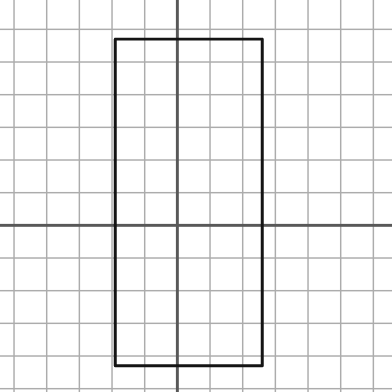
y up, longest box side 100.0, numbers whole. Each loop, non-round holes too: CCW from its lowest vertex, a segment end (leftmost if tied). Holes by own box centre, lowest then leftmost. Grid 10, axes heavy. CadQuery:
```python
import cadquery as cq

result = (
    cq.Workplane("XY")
    .moveTo(-19.0, -43.0)
    .lineTo(26.0, -43.0)
    .lineTo(26.0, 57.0)
    .lineTo(-19.0, 57.0)
    .close()
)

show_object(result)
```